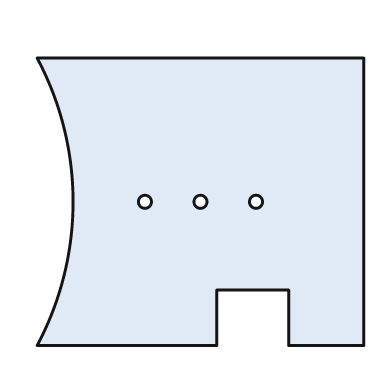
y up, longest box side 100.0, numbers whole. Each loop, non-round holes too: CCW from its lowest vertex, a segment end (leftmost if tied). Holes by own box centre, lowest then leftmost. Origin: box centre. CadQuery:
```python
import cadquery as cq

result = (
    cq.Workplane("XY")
    .moveTo(-50.0, -44.0)
    .lineTo(5.0, -44.0)
    .lineTo(5.0, -27.0)
    .lineTo(27.0, -27.0)
    .lineTo(27.0, -44.0)
    .lineTo(50.0, -44.0)
    .lineTo(50.0, 44.0)
    .lineTo(-50.0, 44.0)
    .threePointArc((-39.0, 0.0), (-50.0, -44.0))
    .close()
    .moveTo(-17.0, 0.0)
    .circle(2.0)
    .moveTo(0.0, 0.0)
    .circle(2.0)
    .moveTo(17.0, 0.0)
    .circle(2.0)
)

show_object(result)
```